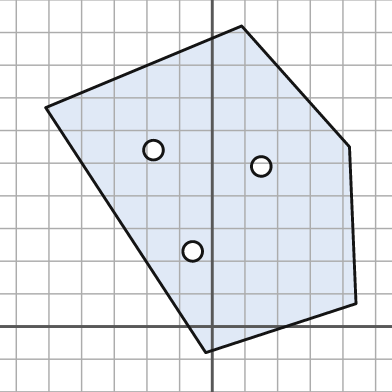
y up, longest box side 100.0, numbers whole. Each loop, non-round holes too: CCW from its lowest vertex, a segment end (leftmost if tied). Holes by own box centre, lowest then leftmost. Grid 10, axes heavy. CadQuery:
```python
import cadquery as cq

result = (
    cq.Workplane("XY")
    .moveTo(-2.0, -8.0)
    .lineTo(44.0, 7.0)
    .lineTo(42.0, 55.0)
    .lineTo(9.0, 92.0)
    .lineTo(-51.0, 67.0)
    .close()
    .moveTo(-6.0, 23.0)
    .circle(3.0)
    .moveTo(15.0, 49.0)
    .circle(3.0)
    .moveTo(-18.0, 54.0)
    .circle(3.0)
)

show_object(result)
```